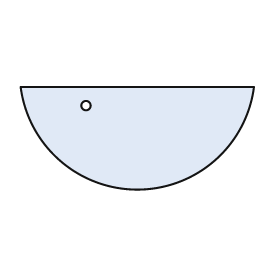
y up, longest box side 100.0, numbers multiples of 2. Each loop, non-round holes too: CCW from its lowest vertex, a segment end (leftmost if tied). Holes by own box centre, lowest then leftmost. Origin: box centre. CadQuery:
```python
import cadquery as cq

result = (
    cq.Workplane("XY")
    .moveTo(-50.0, 22.0)
    .threePointArc((0.0, -22.0), (50.0, 22.0))
    .close()
    .moveTo(-22.0, 14.0)
    .circle(2.0)
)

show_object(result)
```